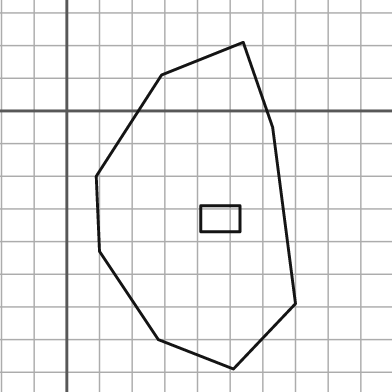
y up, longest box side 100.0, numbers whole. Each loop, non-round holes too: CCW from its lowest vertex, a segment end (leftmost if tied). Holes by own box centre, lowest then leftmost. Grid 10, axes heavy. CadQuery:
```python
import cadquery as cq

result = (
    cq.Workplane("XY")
    .moveTo(51.0, -79.0)
    .lineTo(70.0, -59.0)
    .lineTo(63.0, -5.0)
    .lineTo(54.0, 21.0)
    .lineTo(29.0, 11.0)
    .lineTo(9.0, -20.0)
    .lineTo(10.0, -43.0)
    .lineTo(28.0, -70.0)
    .close()
    .moveTo(41.0, -37.0)
    .lineTo(53.0, -37.0)
    .lineTo(53.0, -29.0)
    .lineTo(41.0, -29.0)
    .close()
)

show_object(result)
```